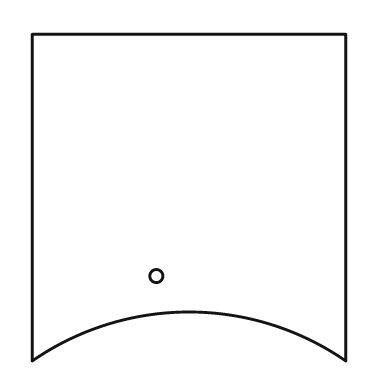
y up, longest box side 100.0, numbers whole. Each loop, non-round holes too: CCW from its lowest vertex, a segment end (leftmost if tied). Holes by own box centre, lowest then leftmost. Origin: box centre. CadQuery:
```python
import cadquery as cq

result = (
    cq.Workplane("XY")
    .moveTo(-48.0, -50.0)
    .threePointArc((0.0, -35.0), (48.0, -50.0))
    .lineTo(48.0, 50.0)
    .lineTo(-48.0, 50.0)
    .close()
    .moveTo(-10.0, -24.0)
    .circle(2.0)
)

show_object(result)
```